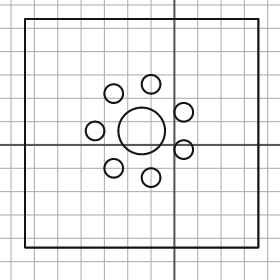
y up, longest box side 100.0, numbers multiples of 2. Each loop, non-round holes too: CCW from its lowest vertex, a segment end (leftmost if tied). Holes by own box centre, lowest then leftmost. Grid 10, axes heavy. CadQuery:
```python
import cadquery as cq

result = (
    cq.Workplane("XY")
    .moveTo(-64.0, -44.0)
    .lineTo(36.0, -44.0)
    .lineTo(36.0, 54.0)
    .lineTo(-64.0, 54.0)
    .close()
    .moveTo(-10.0, -14.0)
    .circle(4.0)
    .moveTo(-26.0, -10.0)
    .circle(4.0)
    .moveTo(4.0, -2.0)
    .circle(4.0)
    .moveTo(-34.0, 6.0)
    .circle(4.0)
    .moveTo(-14.0, 6.0)
    .circle(10.0)
    .moveTo(4.0, 14.0)
    .circle(4.0)
    .moveTo(-26.0, 22.0)
    .circle(4.0)
    .moveTo(-10.0, 26.0)
    .circle(4.0)
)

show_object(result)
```